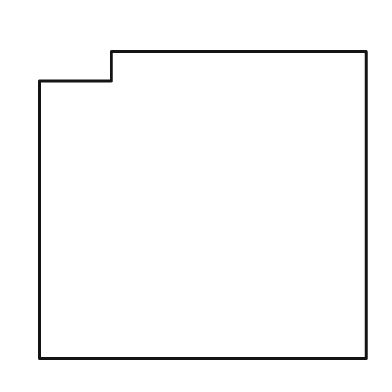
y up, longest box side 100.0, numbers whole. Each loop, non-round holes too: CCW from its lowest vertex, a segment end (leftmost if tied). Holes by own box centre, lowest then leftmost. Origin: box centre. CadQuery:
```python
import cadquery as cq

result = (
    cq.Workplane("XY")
    .moveTo(-50.0, -47.0)
    .lineTo(50.0, -47.0)
    .lineTo(50.0, 47.0)
    .lineTo(-28.0, 47.0)
    .lineTo(-28.0, 38.0)
    .lineTo(-50.0, 38.0)
    .close()
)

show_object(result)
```